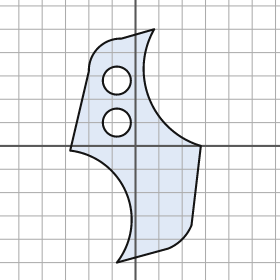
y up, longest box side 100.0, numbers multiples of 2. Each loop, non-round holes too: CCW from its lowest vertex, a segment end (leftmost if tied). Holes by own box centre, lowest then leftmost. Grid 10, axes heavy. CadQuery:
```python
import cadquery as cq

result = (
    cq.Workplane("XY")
    .moveTo(-8.0, -50.0)
    .lineTo(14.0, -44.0)
    .threePointArc((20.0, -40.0), (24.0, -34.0))
    .lineTo(28.0, 0.0)
    .threePointArc((6.0, 20.0), (8.0, 50.0))
    .lineTo(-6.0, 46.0)
    .threePointArc((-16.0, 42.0), (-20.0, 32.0))
    .lineTo(-28.0, -2.0)
    .threePointArc((-4.0, -20.0), (-8.0, -50.0))
    .close()
    .moveTo(-8.0, 10.0)
    .circle(6.0)
    .moveTo(-8.0, 28.0)
    .circle(6.0)
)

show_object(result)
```